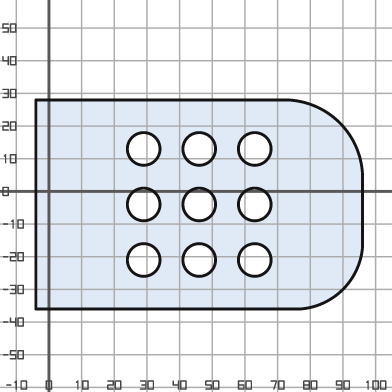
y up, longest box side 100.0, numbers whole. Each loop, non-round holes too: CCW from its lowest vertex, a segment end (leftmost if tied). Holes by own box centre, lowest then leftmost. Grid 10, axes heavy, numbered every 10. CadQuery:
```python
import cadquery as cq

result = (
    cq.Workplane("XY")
    .moveTo(-4.0, -36.0)
    .lineTo(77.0, -36.0)
    .threePointArc((90.0, -30.0), (96.0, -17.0))
    .lineTo(96.0, 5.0)
    .threePointArc((89.0, 21.0), (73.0, 28.0))
    .lineTo(-4.0, 28.0)
    .close()
    .moveTo(29.0, -21.0)
    .circle(5.0)
    .moveTo(46.0, -21.0)
    .circle(5.0)
    .moveTo(63.0, -21.0)
    .circle(5.0)
    .moveTo(29.0, -4.0)
    .circle(5.0)
    .moveTo(46.0, -4.0)
    .circle(5.0)
    .moveTo(63.0, -4.0)
    .circle(5.0)
    .moveTo(29.0, 13.0)
    .circle(5.0)
    .moveTo(46.0, 13.0)
    .circle(5.0)
    .moveTo(63.0, 13.0)
    .circle(5.0)
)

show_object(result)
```